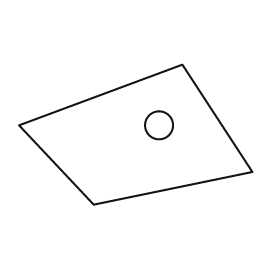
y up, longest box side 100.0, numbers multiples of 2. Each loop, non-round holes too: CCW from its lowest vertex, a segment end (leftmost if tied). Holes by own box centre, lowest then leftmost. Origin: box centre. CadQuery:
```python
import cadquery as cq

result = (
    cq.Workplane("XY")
    .moveTo(-18.0, -30.0)
    .lineTo(50.0, -16.0)
    .lineTo(20.0, 30.0)
    .lineTo(-50.0, 4.0)
    .close()
    .moveTo(10.0, 4.0)
    .circle(6.0)
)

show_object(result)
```